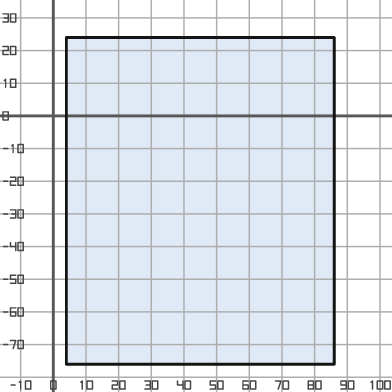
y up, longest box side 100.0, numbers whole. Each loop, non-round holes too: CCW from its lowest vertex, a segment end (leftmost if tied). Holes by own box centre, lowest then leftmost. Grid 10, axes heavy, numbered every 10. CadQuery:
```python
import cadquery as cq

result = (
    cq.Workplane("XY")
    .moveTo(4.0, -76.0)
    .lineTo(86.0, -76.0)
    .lineTo(86.0, 24.0)
    .lineTo(4.0, 24.0)
    .close()
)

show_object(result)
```